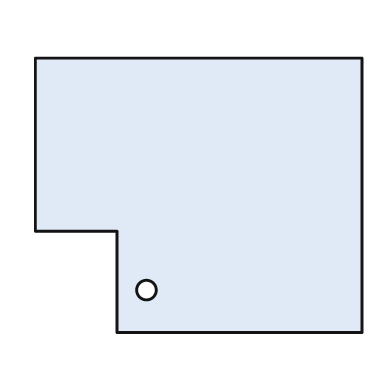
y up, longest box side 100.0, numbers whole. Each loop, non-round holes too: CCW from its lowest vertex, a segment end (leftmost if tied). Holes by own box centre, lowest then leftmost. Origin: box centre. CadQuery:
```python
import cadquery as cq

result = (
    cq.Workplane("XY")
    .moveTo(-25.0, -42.0)
    .lineTo(50.0, -42.0)
    .lineTo(50.0, 42.0)
    .lineTo(-50.0, 42.0)
    .lineTo(-50.0, -11.0)
    .lineTo(-25.0, -11.0)
    .close()
    .moveTo(-16.0, -29.0)
    .circle(3.0)
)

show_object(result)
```